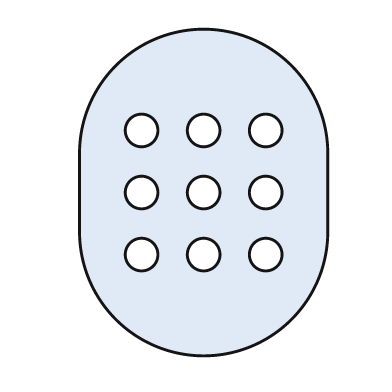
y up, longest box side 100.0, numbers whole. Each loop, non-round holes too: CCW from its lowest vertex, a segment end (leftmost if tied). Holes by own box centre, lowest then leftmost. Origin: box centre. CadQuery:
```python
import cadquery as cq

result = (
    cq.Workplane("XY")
    .moveTo(-38.0, -12.0)
    .threePointArc((0.0, -50.0), (38.0, -12.0))
    .lineTo(38.0, 12.0)
    .threePointArc((0.0, 50.0), (-38.0, 12.0))
    .close()
    .moveTo(-19.0, -19.0)
    .circle(5.0)
    .moveTo(0.0, -19.0)
    .circle(5.0)
    .moveTo(19.0, -19.0)
    .circle(5.0)
    .moveTo(-19.0, 0.0)
    .circle(5.0)
    .moveTo(0.0, 0.0)
    .circle(5.0)
    .moveTo(19.0, 0.0)
    .circle(5.0)
    .moveTo(-19.0, 19.0)
    .circle(5.0)
    .moveTo(0.0, 19.0)
    .circle(5.0)
    .moveTo(19.0, 19.0)
    .circle(5.0)
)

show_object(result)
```